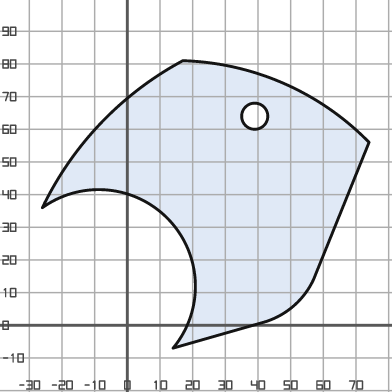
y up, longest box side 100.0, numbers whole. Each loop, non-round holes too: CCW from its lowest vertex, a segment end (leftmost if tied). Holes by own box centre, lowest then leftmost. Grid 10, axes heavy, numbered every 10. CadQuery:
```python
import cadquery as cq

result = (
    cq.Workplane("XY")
    .moveTo(14.0, -7.0)
    .lineTo(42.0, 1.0)
    .threePointArc((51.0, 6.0), (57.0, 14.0))
    .lineTo(74.0, 56.0)
    .threePointArc((48.0, 74.0), (17.0, 81.0))
    .threePointArc((-8.0, 62.0), (-26.0, 36.0))
    .threePointArc((13.0, 32.0), (14.0, -7.0))
    .close()
    .moveTo(39.0, 64.0)
    .circle(4.0)
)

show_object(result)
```